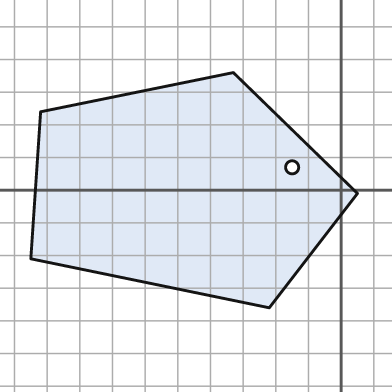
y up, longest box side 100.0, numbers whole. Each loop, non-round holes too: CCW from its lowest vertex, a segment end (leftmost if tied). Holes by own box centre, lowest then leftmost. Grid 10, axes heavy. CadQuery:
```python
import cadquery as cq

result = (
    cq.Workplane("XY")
    .moveTo(-22.0, -36.0)
    .lineTo(5.0, -1.0)
    .lineTo(-33.0, 36.0)
    .lineTo(-92.0, 24.0)
    .lineTo(-95.0, -21.0)
    .close()
    .moveTo(-15.0, 7.0)
    .circle(2.0)
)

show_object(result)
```